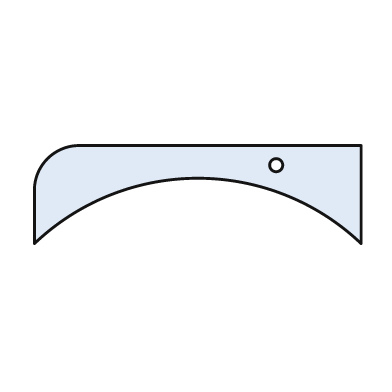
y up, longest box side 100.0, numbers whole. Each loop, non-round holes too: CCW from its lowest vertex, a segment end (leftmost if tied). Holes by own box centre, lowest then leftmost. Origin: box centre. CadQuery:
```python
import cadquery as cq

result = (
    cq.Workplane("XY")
    .moveTo(-50.0, -15.0)
    .threePointArc((0.0, 5.0), (50.0, -15.0))
    .lineTo(50.0, 15.0)
    .lineTo(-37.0, 15.0)
    .threePointArc((-46.0, 11.0), (-50.0, 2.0))
    .close()
    .moveTo(24.0, 9.0)
    .circle(2.0)
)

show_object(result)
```